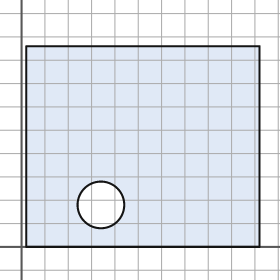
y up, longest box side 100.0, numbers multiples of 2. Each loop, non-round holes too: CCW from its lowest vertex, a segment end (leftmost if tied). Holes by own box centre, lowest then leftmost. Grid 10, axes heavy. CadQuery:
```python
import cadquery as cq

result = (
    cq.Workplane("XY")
    .moveTo(2.0, 0.0)
    .lineTo(102.0, 0.0)
    .lineTo(102.0, 86.0)
    .lineTo(2.0, 86.0)
    .close()
    .moveTo(34.0, 18.0)
    .circle(10.0)
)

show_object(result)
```